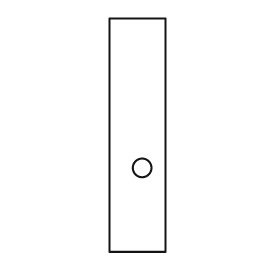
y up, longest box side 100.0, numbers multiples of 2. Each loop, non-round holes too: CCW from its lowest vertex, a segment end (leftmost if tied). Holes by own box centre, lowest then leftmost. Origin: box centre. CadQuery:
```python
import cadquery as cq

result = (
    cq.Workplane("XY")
    .moveTo(-12.0, -50.0)
    .lineTo(12.0, -50.0)
    .lineTo(12.0, 50.0)
    .lineTo(-12.0, 50.0)
    .close()
    .moveTo(2.0, -14.0)
    .circle(4.0)
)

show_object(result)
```